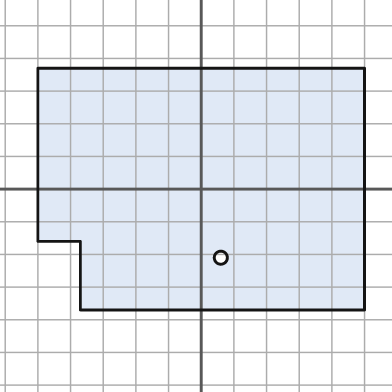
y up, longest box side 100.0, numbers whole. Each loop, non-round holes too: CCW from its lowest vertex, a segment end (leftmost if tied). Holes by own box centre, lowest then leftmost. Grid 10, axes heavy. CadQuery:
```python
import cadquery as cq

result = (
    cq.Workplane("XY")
    .moveTo(-37.0, -37.0)
    .lineTo(50.0, -37.0)
    .lineTo(50.0, 37.0)
    .lineTo(-50.0, 37.0)
    .lineTo(-50.0, -16.0)
    .lineTo(-37.0, -16.0)
    .close()
    .moveTo(6.0, -21.0)
    .circle(2.0)
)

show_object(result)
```